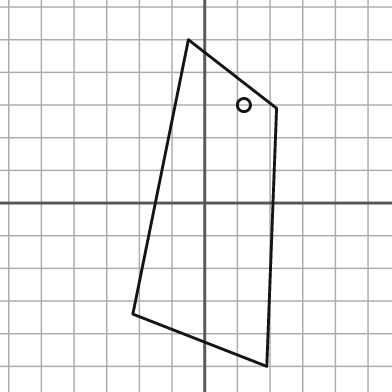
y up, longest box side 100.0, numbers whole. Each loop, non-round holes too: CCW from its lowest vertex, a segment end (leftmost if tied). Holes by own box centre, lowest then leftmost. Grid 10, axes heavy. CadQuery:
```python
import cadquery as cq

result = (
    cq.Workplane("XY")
    .moveTo(19.0, -50.0)
    .lineTo(22.0, 29.0)
    .lineTo(-5.0, 50.0)
    .lineTo(-22.0, -34.0)
    .close()
    .moveTo(12.0, 30.0)
    .circle(2.0)
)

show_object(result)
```